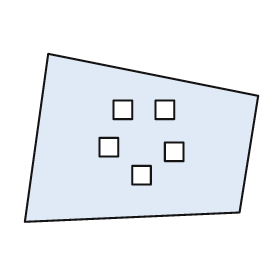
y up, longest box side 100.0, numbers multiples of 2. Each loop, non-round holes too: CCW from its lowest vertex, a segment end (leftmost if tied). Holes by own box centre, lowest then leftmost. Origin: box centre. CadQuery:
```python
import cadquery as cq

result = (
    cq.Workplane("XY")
    .moveTo(-50.0, -36.0)
    .lineTo(42.0, -32.0)
    .lineTo(50.0, 18.0)
    .lineTo(-40.0, 36.0)
    .close()
    .moveTo(-4.0, -20.0)
    .lineTo(4.0, -20.0)
    .lineTo(4.0, -12.0)
    .lineTo(-4.0, -12.0)
    .close()
    .moveTo(10.0, -10.0)
    .lineTo(18.0, -10.0)
    .lineTo(18.0, -2.0)
    .lineTo(10.0, -2.0)
    .close()
    .moveTo(-18.0, -8.0)
    .lineTo(-10.0, -8.0)
    .lineTo(-10.0, 0.0)
    .lineTo(-18.0, 0.0)
    .close()
    .moveTo(-12.0, 8.0)
    .lineTo(-4.0, 8.0)
    .lineTo(-4.0, 16.0)
    .lineTo(-12.0, 16.0)
    .close()
    .moveTo(6.0, 8.0)
    .lineTo(14.0, 8.0)
    .lineTo(14.0, 16.0)
    .lineTo(6.0, 16.0)
    .close()
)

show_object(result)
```